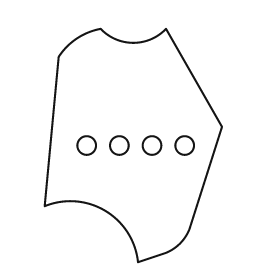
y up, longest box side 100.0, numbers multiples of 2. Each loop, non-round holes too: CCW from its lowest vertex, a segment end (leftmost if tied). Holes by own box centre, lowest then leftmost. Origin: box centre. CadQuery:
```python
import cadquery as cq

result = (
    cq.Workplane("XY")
    .moveTo(2.0, -50.0)
    .lineTo(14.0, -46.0)
    .threePointArc((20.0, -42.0), (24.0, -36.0))
    .lineTo(38.0, 8.0)
    .lineTo(14.0, 50.0)
    .threePointArc((0.0, 44.0), (-14.0, 50.0))
    .threePointArc((-24.0, 46.0), (-32.0, 38.0))
    .lineTo(-38.0, -26.0)
    .threePointArc((-12.0, -28.0), (2.0, -50.0))
    .close()
    .moveTo(-20.0, 0.0)
    .circle(4.0)
    .moveTo(-6.0, 0.0)
    .circle(4.0)
    .moveTo(8.0, 0.0)
    .circle(4.0)
    .moveTo(22.0, 0.0)
    .circle(4.0)
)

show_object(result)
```